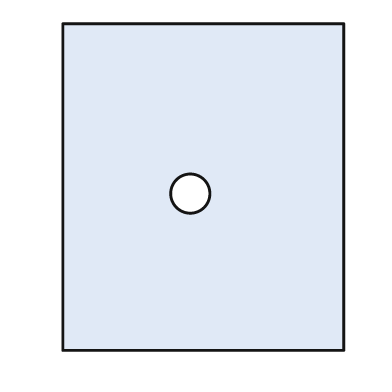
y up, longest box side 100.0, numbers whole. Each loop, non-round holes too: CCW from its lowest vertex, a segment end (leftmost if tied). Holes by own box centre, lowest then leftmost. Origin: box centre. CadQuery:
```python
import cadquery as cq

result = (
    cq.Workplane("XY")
    .moveTo(-43.0, -50.0)
    .lineTo(43.0, -50.0)
    .lineTo(43.0, 50.0)
    .lineTo(-43.0, 50.0)
    .close()
    .moveTo(-4.0, -2.0)
    .circle(6.0)
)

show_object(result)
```